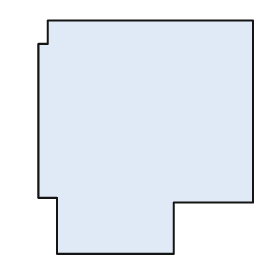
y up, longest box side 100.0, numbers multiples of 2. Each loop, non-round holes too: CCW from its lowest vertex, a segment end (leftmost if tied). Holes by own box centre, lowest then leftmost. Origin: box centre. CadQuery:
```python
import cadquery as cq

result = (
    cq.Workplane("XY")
    .moveTo(-38.0, -50.0)
    .lineTo(12.0, -50.0)
    .lineTo(12.0, -28.0)
    .lineTo(46.0, -28.0)
    .lineTo(46.0, 50.0)
    .lineTo(-42.0, 50.0)
    .lineTo(-42.0, 40.0)
    .lineTo(-46.0, 40.0)
    .lineTo(-46.0, -26.0)
    .lineTo(-38.0, -26.0)
    .close()
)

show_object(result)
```